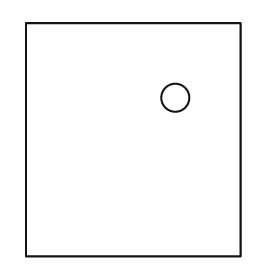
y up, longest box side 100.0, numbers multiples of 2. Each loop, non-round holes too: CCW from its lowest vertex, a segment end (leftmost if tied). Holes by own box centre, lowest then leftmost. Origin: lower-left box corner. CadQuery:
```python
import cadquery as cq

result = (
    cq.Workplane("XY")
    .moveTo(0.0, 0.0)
    .lineTo(92.0, 0.0)
    .lineTo(92.0, 100.0)
    .lineTo(0.0, 100.0)
    .close()
    .moveTo(64.0, 68.0)
    .circle(6.0)
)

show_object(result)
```